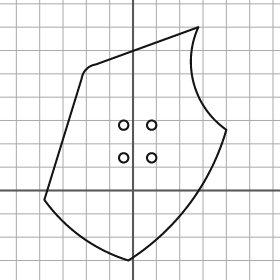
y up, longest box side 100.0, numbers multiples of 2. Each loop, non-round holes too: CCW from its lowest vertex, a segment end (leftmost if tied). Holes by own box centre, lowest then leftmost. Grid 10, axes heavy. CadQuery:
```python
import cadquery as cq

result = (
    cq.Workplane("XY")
    .moveTo(-2.0, -30.0)
    .threePointArc((24.0, -6.0), (40.0, 26.0))
    .threePointArc((26.0, 46.0), (28.0, 70.0))
    .lineTo(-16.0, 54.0)
    .threePointArc((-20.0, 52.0), (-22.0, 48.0))
    .lineTo(-38.0, -4.0)
    .threePointArc((-22.0, -20.0), (-2.0, -30.0))
    .close()
    .moveTo(-4.0, 14.0)
    .circle(2.0)
    .moveTo(8.0, 14.0)
    .circle(2.0)
    .moveTo(-4.0, 28.0)
    .circle(2.0)
    .moveTo(8.0, 28.0)
    .circle(2.0)
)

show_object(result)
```